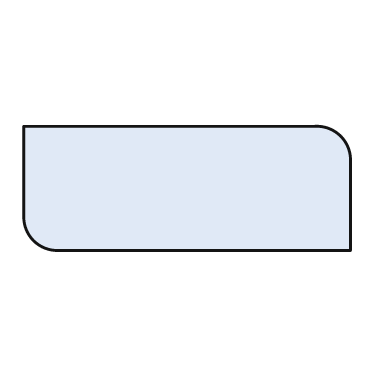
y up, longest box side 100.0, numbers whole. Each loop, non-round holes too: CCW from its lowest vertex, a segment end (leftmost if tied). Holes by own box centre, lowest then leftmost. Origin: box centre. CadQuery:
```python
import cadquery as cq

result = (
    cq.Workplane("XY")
    .moveTo(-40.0, -19.0)
    .lineTo(50.0, -19.0)
    .lineTo(50.0, 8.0)
    .threePointArc((47.0, 16.0), (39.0, 19.0))
    .lineTo(-50.0, 19.0)
    .lineTo(-50.0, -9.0)
    .threePointArc((-47.0, -16.0), (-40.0, -19.0))
    .close()
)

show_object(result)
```